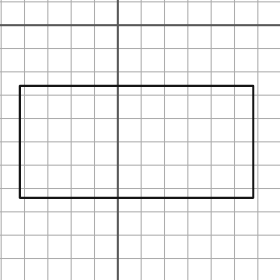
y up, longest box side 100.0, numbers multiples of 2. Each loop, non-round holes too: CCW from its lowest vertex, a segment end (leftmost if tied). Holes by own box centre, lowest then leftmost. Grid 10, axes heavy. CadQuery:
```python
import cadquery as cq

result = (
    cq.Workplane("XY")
    .moveTo(-42.0, -74.0)
    .lineTo(58.0, -74.0)
    .lineTo(58.0, -26.0)
    .lineTo(-42.0, -26.0)
    .close()
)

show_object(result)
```